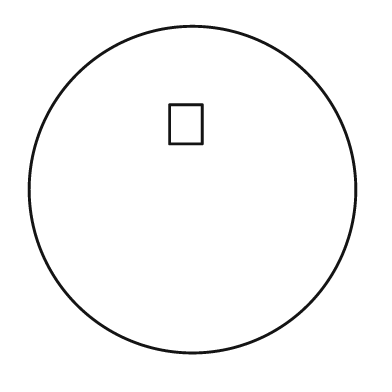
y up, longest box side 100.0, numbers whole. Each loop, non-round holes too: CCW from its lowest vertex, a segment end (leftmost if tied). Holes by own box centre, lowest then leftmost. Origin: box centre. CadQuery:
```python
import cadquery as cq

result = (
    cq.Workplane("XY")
    .moveTo(0.0, 0.0)
    .circle(50.0)
    .moveTo(-7.0, 14.0)
    .lineTo(3.0, 14.0)
    .lineTo(3.0, 26.0)
    .lineTo(-7.0, 26.0)
    .close()
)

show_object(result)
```